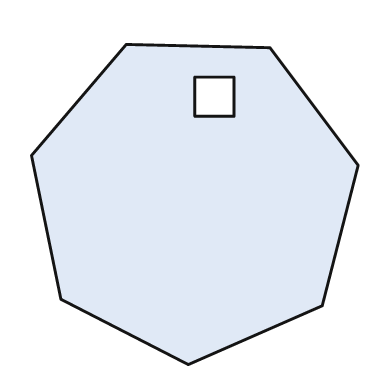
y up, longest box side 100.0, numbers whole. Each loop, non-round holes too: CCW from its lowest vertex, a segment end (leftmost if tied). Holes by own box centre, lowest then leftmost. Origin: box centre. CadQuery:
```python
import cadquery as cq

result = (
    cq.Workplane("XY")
    .moveTo(-2.0, -49.0)
    .lineTo(39.0, -31.0)
    .lineTo(50.0, 12.0)
    .lineTo(23.0, 48.0)
    .lineTo(-21.0, 49.0)
    .lineTo(-50.0, 15.0)
    .lineTo(-41.0, -29.0)
    .close()
    .moveTo(0.0, 27.0)
    .lineTo(12.0, 27.0)
    .lineTo(12.0, 39.0)
    .lineTo(0.0, 39.0)
    .close()
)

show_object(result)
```